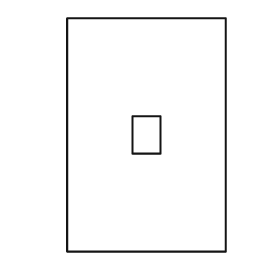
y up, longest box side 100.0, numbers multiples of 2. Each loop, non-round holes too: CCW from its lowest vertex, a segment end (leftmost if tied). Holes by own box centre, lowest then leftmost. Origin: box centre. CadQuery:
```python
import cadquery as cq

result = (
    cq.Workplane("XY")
    .moveTo(-34.0, -50.0)
    .lineTo(34.0, -50.0)
    .lineTo(34.0, 50.0)
    .lineTo(-34.0, 50.0)
    .close()
    .moveTo(-6.0, -8.0)
    .lineTo(6.0, -8.0)
    .lineTo(6.0, 8.0)
    .lineTo(-6.0, 8.0)
    .close()
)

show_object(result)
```